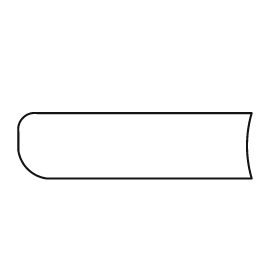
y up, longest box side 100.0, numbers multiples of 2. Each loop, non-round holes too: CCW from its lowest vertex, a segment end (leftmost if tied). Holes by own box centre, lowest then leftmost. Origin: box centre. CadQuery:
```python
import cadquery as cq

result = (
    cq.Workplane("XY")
    .moveTo(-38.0, -14.0)
    .lineTo(50.0, -14.0)
    .threePointArc((48.0, 0.0), (50.0, 14.0))
    .lineTo(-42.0, 14.0)
    .threePointArc((-48.0, 12.0), (-50.0, 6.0))
    .lineTo(-50.0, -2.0)
    .threePointArc((-46.0, -10.0), (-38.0, -14.0))
    .close()
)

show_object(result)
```